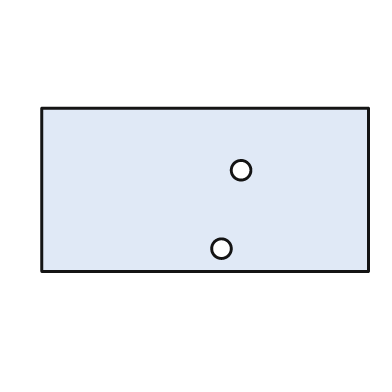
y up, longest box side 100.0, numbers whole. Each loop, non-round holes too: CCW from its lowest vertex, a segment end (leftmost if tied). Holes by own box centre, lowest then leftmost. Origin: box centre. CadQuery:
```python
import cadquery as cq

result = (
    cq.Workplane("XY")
    .moveTo(-50.0, -25.0)
    .lineTo(50.0, -25.0)
    .lineTo(50.0, 25.0)
    .lineTo(-50.0, 25.0)
    .close()
    .moveTo(5.0, -18.0)
    .circle(3.0)
    .moveTo(11.0, 6.0)
    .circle(3.0)
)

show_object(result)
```